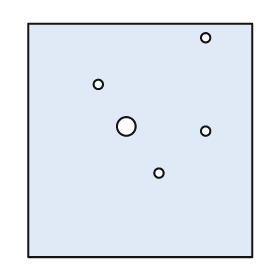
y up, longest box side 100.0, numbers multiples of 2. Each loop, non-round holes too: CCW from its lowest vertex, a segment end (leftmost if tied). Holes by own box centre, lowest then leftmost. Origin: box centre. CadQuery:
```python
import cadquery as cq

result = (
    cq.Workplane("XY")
    .moveTo(-48.0, -50.0)
    .lineTo(48.0, -50.0)
    .lineTo(48.0, 50.0)
    .lineTo(-48.0, 50.0)
    .close()
    .moveTo(8.0, -14.0)
    .circle(2.0)
    .moveTo(28.0, 4.0)
    .circle(2.0)
    .moveTo(-6.0, 6.0)
    .circle(4.0)
    .moveTo(-18.0, 24.0)
    .circle(2.0)
    .moveTo(28.0, 44.0)
    .circle(2.0)
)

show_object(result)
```